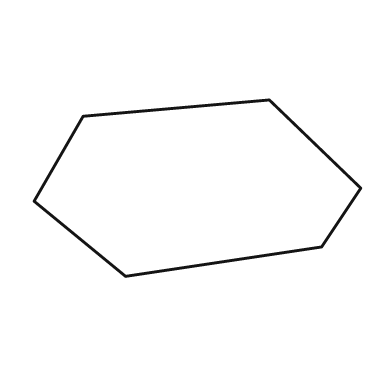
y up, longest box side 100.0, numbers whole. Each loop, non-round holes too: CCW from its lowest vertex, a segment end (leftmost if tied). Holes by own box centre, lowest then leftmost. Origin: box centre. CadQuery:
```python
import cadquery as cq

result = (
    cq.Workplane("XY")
    .moveTo(-22.0, -27.0)
    .lineTo(38.0, -18.0)
    .lineTo(50.0, 0.0)
    .lineTo(22.0, 27.0)
    .lineTo(-35.0, 22.0)
    .lineTo(-50.0, -4.0)
    .close()
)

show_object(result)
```